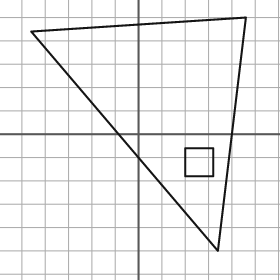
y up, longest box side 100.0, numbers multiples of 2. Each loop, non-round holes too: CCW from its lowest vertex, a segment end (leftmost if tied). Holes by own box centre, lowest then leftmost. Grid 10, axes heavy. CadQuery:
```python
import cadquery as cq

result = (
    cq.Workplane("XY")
    .moveTo(34.0, -50.0)
    .lineTo(46.0, 50.0)
    .lineTo(-46.0, 44.0)
    .close()
    .moveTo(20.0, -18.0)
    .lineTo(32.0, -18.0)
    .lineTo(32.0, -6.0)
    .lineTo(20.0, -6.0)
    .close()
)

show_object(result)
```